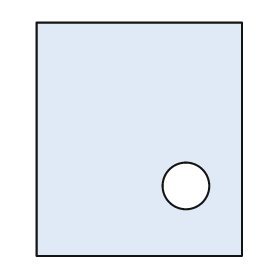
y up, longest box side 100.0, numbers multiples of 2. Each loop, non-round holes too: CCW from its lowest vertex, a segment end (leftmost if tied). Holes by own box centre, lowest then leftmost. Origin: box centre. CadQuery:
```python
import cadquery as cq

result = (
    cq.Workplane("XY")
    .moveTo(-44.0, -50.0)
    .lineTo(44.0, -50.0)
    .lineTo(44.0, 50.0)
    .lineTo(-44.0, 50.0)
    .close()
    .moveTo(20.0, -20.0)
    .circle(10.0)
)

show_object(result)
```